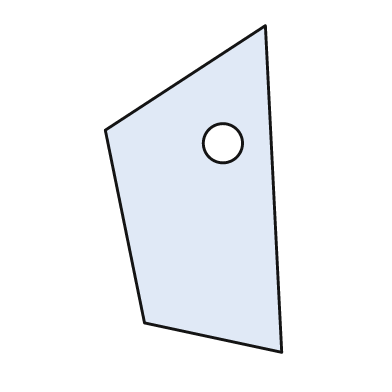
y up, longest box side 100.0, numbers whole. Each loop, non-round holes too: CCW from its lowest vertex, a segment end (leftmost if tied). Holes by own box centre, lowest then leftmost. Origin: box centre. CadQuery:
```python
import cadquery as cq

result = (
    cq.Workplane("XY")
    .moveTo(27.0, -50.0)
    .lineTo(22.0, 50.0)
    .lineTo(-27.0, 18.0)
    .lineTo(-15.0, -41.0)
    .close()
    .moveTo(9.0, 14.0)
    .circle(6.0)
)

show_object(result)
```